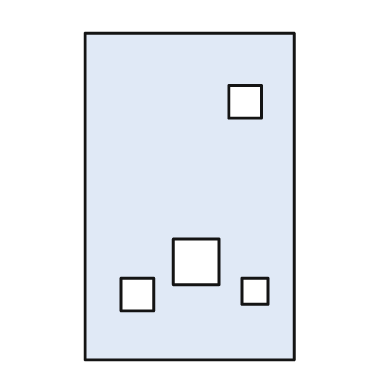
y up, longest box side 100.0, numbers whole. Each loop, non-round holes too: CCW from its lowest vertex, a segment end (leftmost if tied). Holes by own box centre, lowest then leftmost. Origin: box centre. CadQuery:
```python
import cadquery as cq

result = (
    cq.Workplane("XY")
    .moveTo(-32.0, -50.0)
    .lineTo(32.0, -50.0)
    .lineTo(32.0, 50.0)
    .lineTo(-32.0, 50.0)
    .close()
    .moveTo(-21.0, -35.0)
    .lineTo(-11.0, -35.0)
    .lineTo(-11.0, -25.0)
    .lineTo(-21.0, -25.0)
    .close()
    .moveTo(16.0, -33.0)
    .lineTo(24.0, -33.0)
    .lineTo(24.0, -25.0)
    .lineTo(16.0, -25.0)
    .close()
    .moveTo(-5.0, -27.0)
    .lineTo(9.0, -27.0)
    .lineTo(9.0, -13.0)
    .lineTo(-5.0, -13.0)
    .close()
    .moveTo(12.0, 24.0)
    .lineTo(22.0, 24.0)
    .lineTo(22.0, 34.0)
    .lineTo(12.0, 34.0)
    .close()
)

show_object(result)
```